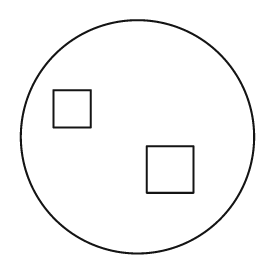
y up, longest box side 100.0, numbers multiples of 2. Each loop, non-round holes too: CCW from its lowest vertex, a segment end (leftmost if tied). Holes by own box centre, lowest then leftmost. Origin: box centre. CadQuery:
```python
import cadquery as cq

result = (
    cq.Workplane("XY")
    .moveTo(0.0, 0.0)
    .circle(50.0)
    .moveTo(4.0, -24.0)
    .lineTo(24.0, -24.0)
    .lineTo(24.0, -4.0)
    .lineTo(4.0, -4.0)
    .close()
    .moveTo(-36.0, 4.0)
    .lineTo(-20.0, 4.0)
    .lineTo(-20.0, 20.0)
    .lineTo(-36.0, 20.0)
    .close()
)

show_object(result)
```